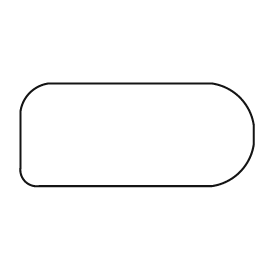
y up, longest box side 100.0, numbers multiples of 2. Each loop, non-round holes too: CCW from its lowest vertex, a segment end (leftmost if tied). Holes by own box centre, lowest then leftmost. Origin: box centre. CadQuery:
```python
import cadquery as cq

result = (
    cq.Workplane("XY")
    .moveTo(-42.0, -22.0)
    .lineTo(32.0, -22.0)
    .threePointArc((44.0, -16.0), (50.0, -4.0))
    .lineTo(50.0, 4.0)
    .threePointArc((44.0, 16.0), (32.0, 22.0))
    .lineTo(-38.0, 22.0)
    .threePointArc((-46.0, 18.0), (-50.0, 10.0))
    .lineTo(-50.0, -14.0)
    .threePointArc((-48.0, -20.0), (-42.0, -22.0))
    .close()
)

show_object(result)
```